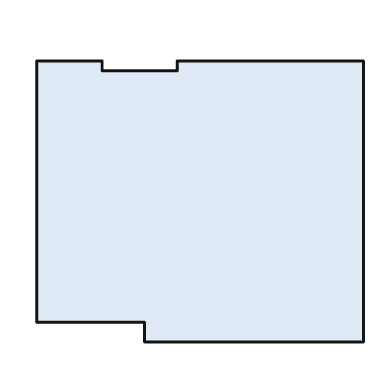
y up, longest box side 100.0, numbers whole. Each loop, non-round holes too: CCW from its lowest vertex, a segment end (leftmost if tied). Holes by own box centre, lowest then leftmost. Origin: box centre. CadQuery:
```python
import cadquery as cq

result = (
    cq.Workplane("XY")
    .moveTo(-17.0, -43.0)
    .lineTo(50.0, -43.0)
    .lineTo(50.0, 43.0)
    .lineTo(-7.0, 43.0)
    .lineTo(-7.0, 40.0)
    .lineTo(-30.0, 40.0)
    .lineTo(-30.0, 43.0)
    .lineTo(-50.0, 43.0)
    .lineTo(-50.0, -37.0)
    .lineTo(-17.0, -37.0)
    .close()
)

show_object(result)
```